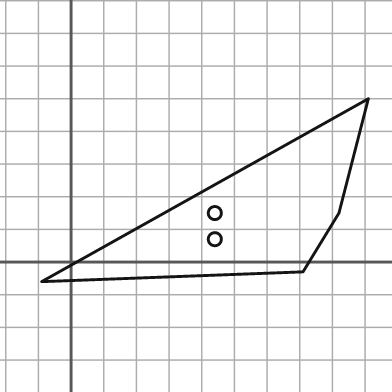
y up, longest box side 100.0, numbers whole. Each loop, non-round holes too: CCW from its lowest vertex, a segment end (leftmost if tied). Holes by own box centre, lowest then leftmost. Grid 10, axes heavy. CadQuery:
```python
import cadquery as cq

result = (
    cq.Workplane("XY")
    .moveTo(-9.0, -6.0)
    .lineTo(71.0, -3.0)
    .lineTo(82.0, 15.0)
    .lineTo(91.0, 50.0)
    .close()
    .moveTo(44.0, 7.0)
    .circle(2.0)
    .moveTo(44.0, 15.0)
    .circle(2.0)
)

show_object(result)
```